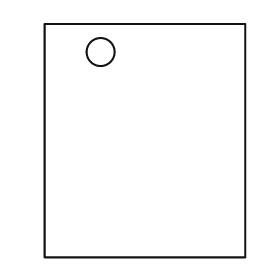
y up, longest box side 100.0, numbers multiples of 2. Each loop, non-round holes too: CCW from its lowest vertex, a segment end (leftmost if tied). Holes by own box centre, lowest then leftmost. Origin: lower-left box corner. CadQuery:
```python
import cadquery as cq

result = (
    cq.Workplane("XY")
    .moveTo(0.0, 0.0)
    .lineTo(86.0, 0.0)
    .lineTo(86.0, 100.0)
    .lineTo(0.0, 100.0)
    .close()
    .moveTo(24.0, 88.0)
    .circle(6.0)
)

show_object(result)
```